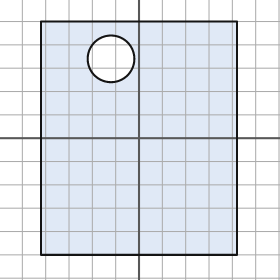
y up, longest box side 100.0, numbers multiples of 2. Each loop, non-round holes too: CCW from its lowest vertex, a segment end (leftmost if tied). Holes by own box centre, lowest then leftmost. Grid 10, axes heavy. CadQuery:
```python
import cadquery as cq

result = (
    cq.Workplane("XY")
    .moveTo(-42.0, -50.0)
    .lineTo(42.0, -50.0)
    .lineTo(42.0, 50.0)
    .lineTo(-42.0, 50.0)
    .close()
    .moveTo(-12.0, 34.0)
    .circle(10.0)
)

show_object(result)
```